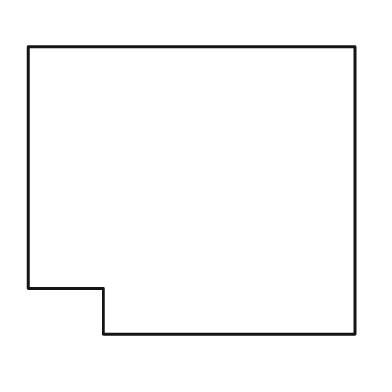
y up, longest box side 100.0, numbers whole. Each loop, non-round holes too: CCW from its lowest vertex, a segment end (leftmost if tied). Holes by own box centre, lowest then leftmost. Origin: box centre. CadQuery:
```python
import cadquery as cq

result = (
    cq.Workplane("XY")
    .moveTo(-27.0, -44.0)
    .lineTo(50.0, -44.0)
    .lineTo(50.0, 44.0)
    .lineTo(-50.0, 44.0)
    .lineTo(-50.0, -30.0)
    .lineTo(-27.0, -30.0)
    .close()
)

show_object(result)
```